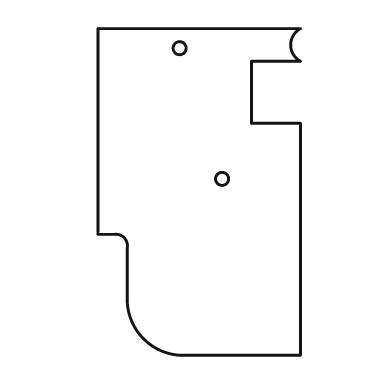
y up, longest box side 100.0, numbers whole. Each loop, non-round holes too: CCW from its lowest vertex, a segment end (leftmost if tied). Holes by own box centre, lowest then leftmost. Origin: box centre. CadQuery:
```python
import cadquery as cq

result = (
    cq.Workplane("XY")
    .moveTo(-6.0, -50.0)
    .lineTo(31.0, -50.0)
    .lineTo(31.0, 21.0)
    .lineTo(16.0, 21.0)
    .lineTo(16.0, 40.0)
    .lineTo(31.0, 40.0)
    .threePointArc((28.0, 45.0), (31.0, 50.0))
    .lineTo(-31.0, 50.0)
    .lineTo(-31.0, -13.0)
    .lineTo(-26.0, -13.0)
    .threePointArc((-23.0, -14.0), (-22.0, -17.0))
    .lineTo(-22.0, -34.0)
    .threePointArc((-17.0, -45.0), (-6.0, -50.0))
    .close()
    .moveTo(7.0, 4.0)
    .circle(2.0)
    .moveTo(-6.0, 44.0)
    .circle(2.0)
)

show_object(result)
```